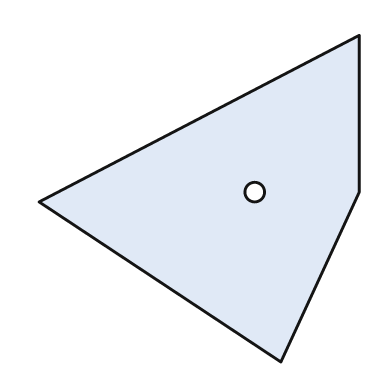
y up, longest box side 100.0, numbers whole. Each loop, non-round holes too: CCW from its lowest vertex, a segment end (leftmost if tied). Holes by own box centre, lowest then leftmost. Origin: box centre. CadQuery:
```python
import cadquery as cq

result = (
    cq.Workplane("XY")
    .moveTo(25.0, -50.0)
    .lineTo(49.0, 2.0)
    .lineTo(49.0, 50.0)
    .lineTo(-49.0, -1.0)
    .close()
    .moveTo(17.0, 2.0)
    .circle(3.0)
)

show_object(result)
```